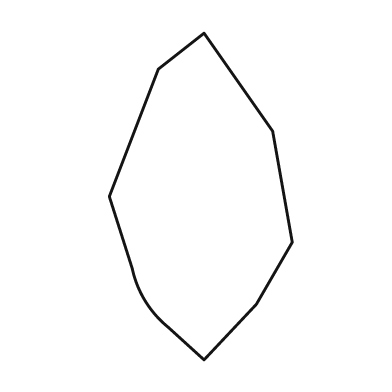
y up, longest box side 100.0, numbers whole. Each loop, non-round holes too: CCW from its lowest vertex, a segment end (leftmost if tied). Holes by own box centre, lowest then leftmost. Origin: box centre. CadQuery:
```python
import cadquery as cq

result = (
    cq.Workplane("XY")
    .moveTo(1.0, -50.0)
    .lineTo(17.0, -33.0)
    .lineTo(28.0, -14.0)
    .lineTo(22.0, 20.0)
    .lineTo(1.0, 50.0)
    .lineTo(-13.0, 39.0)
    .lineTo(-28.0, 0.0)
    .lineTo(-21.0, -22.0)
    .threePointArc((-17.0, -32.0), (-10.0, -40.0))
    .close()
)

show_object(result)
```